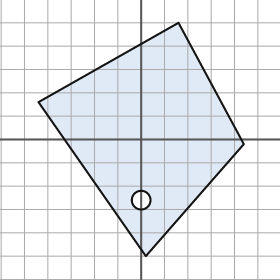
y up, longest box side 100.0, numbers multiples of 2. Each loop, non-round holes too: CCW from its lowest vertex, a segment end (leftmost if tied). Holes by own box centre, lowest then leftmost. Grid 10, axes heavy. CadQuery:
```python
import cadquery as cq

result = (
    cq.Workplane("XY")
    .moveTo(2.0, -50.0)
    .lineTo(44.0, -2.0)
    .lineTo(16.0, 50.0)
    .lineTo(-44.0, 16.0)
    .close()
    .moveTo(0.0, -26.0)
    .circle(4.0)
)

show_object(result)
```